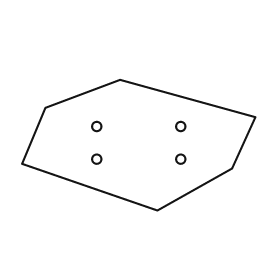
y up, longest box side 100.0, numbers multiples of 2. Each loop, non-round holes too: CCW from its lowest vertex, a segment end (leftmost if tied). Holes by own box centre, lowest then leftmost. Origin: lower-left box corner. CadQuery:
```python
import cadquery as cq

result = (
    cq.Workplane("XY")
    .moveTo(58.0, 0.0)
    .lineTo(90.0, 18.0)
    .lineTo(100.0, 40.0)
    .lineTo(42.0, 56.0)
    .lineTo(10.0, 44.0)
    .lineTo(0.0, 20.0)
    .close()
    .moveTo(32.0, 22.0)
    .circle(2.0)
    .moveTo(68.0, 22.0)
    .circle(2.0)
    .moveTo(32.0, 36.0)
    .circle(2.0)
    .moveTo(68.0, 36.0)
    .circle(2.0)
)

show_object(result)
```